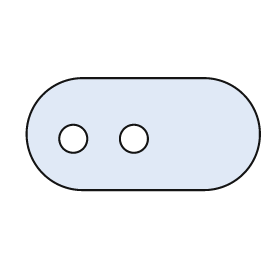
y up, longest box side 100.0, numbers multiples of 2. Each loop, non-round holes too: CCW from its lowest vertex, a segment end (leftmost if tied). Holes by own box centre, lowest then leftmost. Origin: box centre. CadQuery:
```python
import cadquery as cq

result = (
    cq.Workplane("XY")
    .moveTo(-26.0, -24.0)
    .lineTo(26.0, -24.0)
    .threePointArc((50.0, 0.0), (26.0, 24.0))
    .lineTo(-26.0, 24.0)
    .threePointArc((-50.0, 0.0), (-26.0, -24.0))
    .close()
    .moveTo(-30.0, -2.0)
    .circle(6.0)
    .moveTo(-4.0, -2.0)
    .circle(6.0)
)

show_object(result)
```